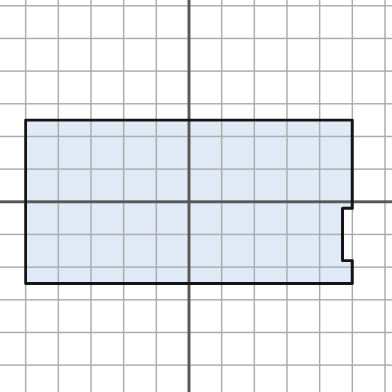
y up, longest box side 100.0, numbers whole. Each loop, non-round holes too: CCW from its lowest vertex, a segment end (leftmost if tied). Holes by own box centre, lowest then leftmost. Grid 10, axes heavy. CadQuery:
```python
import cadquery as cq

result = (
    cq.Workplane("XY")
    .moveTo(-50.0, -25.0)
    .lineTo(50.0, -25.0)
    .lineTo(50.0, -18.0)
    .lineTo(47.0, -18.0)
    .lineTo(47.0, -2.0)
    .lineTo(50.0, -2.0)
    .lineTo(50.0, 25.0)
    .lineTo(-50.0, 25.0)
    .close()
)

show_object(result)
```